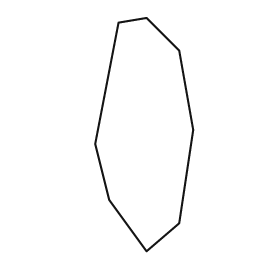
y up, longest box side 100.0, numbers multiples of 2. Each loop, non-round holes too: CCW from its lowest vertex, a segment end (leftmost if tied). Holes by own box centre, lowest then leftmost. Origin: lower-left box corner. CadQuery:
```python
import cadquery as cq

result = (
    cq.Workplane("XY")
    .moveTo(22.0, 0.0)
    .lineTo(36.0, 12.0)
    .lineTo(42.0, 52.0)
    .lineTo(36.0, 86.0)
    .lineTo(22.0, 100.0)
    .lineTo(10.0, 98.0)
    .lineTo(0.0, 46.0)
    .lineTo(6.0, 22.0)
    .close()
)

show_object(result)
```